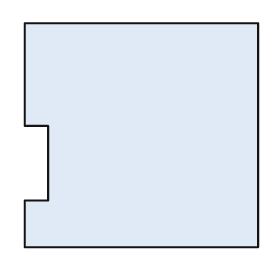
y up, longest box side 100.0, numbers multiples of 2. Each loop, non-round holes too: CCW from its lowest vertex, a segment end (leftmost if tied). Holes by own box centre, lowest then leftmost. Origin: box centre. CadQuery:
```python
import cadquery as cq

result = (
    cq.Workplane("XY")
    .moveTo(-50.0, -48.0)
    .lineTo(50.0, -48.0)
    .lineTo(50.0, 48.0)
    .lineTo(-50.0, 48.0)
    .lineTo(-50.0, 4.0)
    .lineTo(-40.0, 4.0)
    .lineTo(-40.0, -28.0)
    .lineTo(-50.0, -28.0)
    .close()
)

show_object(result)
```